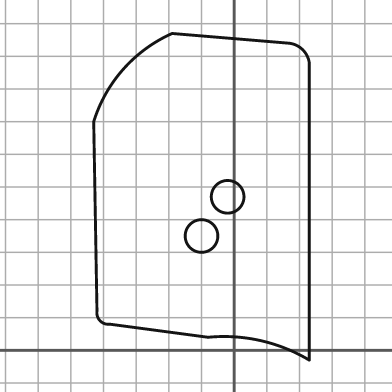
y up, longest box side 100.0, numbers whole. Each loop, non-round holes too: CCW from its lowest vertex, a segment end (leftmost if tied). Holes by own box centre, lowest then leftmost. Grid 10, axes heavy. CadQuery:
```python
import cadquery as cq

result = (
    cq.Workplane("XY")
    .moveTo(23.0, -3.0)
    .lineTo(23.0, 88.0)
    .threePointArc((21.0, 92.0), (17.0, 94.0))
    .lineTo(-19.0, 97.0)
    .threePointArc((-34.0, 86.0), (-43.0, 70.0))
    .lineTo(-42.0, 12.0)
    .threePointArc((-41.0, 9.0), (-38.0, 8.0))
    .lineTo(-8.0, 4.0)
    .threePointArc((8.0, 3.0), (23.0, -3.0))
    .close()
    .moveTo(-10.0, 35.0)
    .circle(5.0)
    .moveTo(-2.0, 47.0)
    .circle(5.0)
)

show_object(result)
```